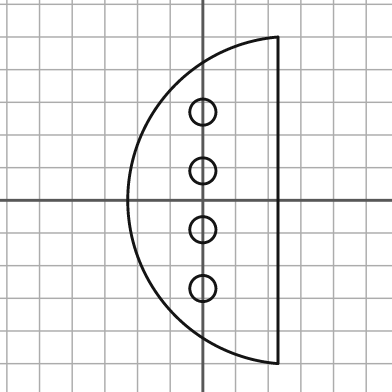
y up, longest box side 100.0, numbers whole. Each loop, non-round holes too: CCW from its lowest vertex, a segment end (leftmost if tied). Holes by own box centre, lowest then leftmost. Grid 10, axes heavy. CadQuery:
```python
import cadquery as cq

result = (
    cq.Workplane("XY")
    .moveTo(23.0, -50.0)
    .lineTo(23.0, 50.0)
    .threePointArc((-23.0, 0.0), (23.0, -50.0))
    .close()
    .moveTo(0.0, -27.0)
    .circle(4.0)
    .moveTo(0.0, -9.0)
    .circle(4.0)
    .moveTo(0.0, 9.0)
    .circle(4.0)
    .moveTo(0.0, 27.0)
    .circle(4.0)
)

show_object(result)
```